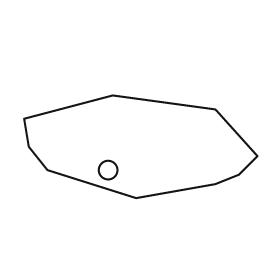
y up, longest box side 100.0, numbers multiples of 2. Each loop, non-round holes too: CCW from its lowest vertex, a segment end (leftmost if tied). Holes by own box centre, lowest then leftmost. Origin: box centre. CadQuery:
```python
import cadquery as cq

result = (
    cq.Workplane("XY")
    .moveTo(-2.0, -22.0)
    .lineTo(32.0, -16.0)
    .lineTo(42.0, -12.0)
    .lineTo(50.0, -4.0)
    .lineTo(32.0, 16.0)
    .lineTo(-12.0, 22.0)
    .lineTo(-50.0, 12.0)
    .lineTo(-48.0, 0.0)
    .lineTo(-40.0, -10.0)
    .close()
    .moveTo(-14.0, -10.0)
    .circle(4.0)
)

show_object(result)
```